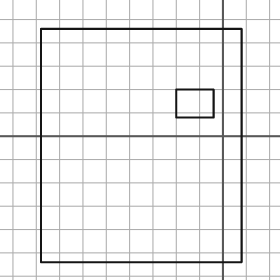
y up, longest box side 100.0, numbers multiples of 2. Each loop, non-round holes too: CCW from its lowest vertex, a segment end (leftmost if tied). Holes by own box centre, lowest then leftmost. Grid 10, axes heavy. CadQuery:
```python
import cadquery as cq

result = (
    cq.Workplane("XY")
    .moveTo(-78.0, -54.0)
    .lineTo(8.0, -54.0)
    .lineTo(8.0, 46.0)
    .lineTo(-78.0, 46.0)
    .close()
    .moveTo(-20.0, 8.0)
    .lineTo(-4.0, 8.0)
    .lineTo(-4.0, 20.0)
    .lineTo(-20.0, 20.0)
    .close()
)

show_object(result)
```